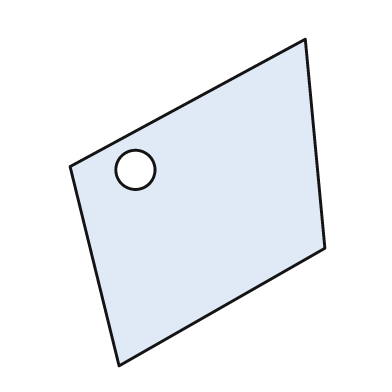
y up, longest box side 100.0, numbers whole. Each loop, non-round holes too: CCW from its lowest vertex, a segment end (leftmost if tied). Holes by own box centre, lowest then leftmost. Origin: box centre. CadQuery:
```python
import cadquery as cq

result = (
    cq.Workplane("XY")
    .moveTo(-24.0, -50.0)
    .lineTo(39.0, -14.0)
    .lineTo(33.0, 50.0)
    .lineTo(-39.0, 11.0)
    .close()
    .moveTo(-19.0, 10.0)
    .circle(6.0)
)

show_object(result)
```